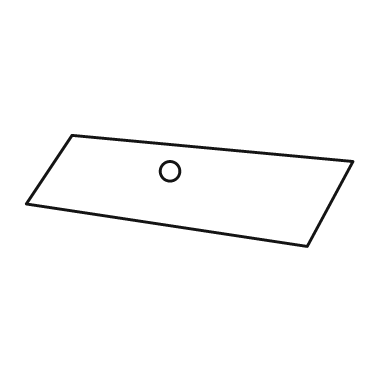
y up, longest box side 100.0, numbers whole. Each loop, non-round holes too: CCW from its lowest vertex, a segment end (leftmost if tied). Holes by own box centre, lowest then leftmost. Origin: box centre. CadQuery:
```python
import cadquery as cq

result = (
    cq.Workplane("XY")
    .moveTo(36.0, -17.0)
    .lineTo(50.0, 9.0)
    .lineTo(-36.0, 17.0)
    .lineTo(-50.0, -4.0)
    .close()
    .moveTo(-6.0, 6.0)
    .circle(3.0)
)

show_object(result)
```